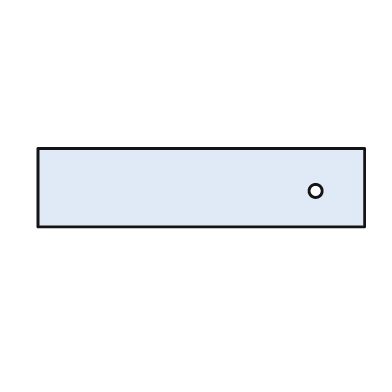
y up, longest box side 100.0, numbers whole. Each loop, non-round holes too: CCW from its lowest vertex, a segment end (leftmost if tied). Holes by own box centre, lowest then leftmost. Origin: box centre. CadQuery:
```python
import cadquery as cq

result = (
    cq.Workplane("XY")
    .moveTo(-50.0, -12.0)
    .lineTo(50.0, -12.0)
    .lineTo(50.0, 12.0)
    .lineTo(-50.0, 12.0)
    .close()
    .moveTo(35.0, -1.0)
    .circle(2.0)
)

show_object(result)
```